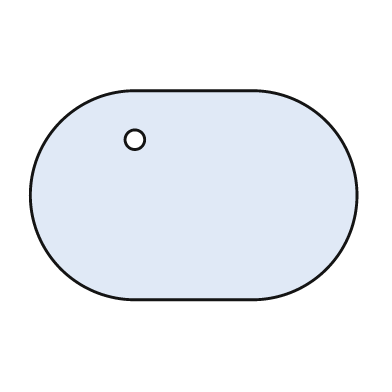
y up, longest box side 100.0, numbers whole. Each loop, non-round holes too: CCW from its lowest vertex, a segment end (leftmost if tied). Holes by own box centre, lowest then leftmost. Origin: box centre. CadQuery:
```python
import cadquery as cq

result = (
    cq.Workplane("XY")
    .moveTo(-18.0, -32.0)
    .lineTo(18.0, -32.0)
    .threePointArc((50.0, 0.0), (18.0, 32.0))
    .lineTo(-18.0, 32.0)
    .threePointArc((-50.0, 0.0), (-18.0, -32.0))
    .close()
    .moveTo(-18.0, 17.0)
    .circle(3.0)
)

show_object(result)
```